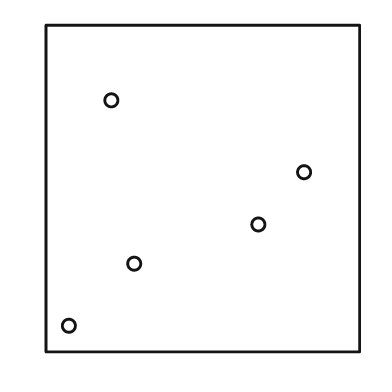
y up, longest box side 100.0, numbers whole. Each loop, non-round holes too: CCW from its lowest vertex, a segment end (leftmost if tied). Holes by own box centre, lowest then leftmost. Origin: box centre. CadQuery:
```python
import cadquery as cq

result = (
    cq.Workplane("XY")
    .moveTo(-48.0, -50.0)
    .lineTo(48.0, -50.0)
    .lineTo(48.0, 50.0)
    .lineTo(-48.0, 50.0)
    .close()
    .moveTo(-41.0, -42.0)
    .circle(2.0)
    .moveTo(-21.0, -23.0)
    .circle(2.0)
    .moveTo(17.0, -11.0)
    .circle(2.0)
    .moveTo(31.0, 5.0)
    .circle(2.0)
    .moveTo(-28.0, 27.0)
    .circle(2.0)
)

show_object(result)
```